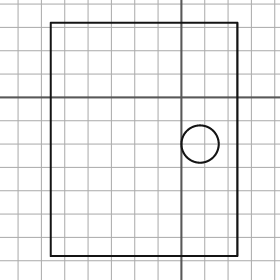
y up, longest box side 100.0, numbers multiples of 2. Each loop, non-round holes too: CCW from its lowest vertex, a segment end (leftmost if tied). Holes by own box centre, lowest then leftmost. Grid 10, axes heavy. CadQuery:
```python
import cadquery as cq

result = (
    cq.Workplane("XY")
    .moveTo(-56.0, -68.0)
    .lineTo(24.0, -68.0)
    .lineTo(24.0, 32.0)
    .lineTo(-56.0, 32.0)
    .close()
    .moveTo(8.0, -20.0)
    .circle(8.0)
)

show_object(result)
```